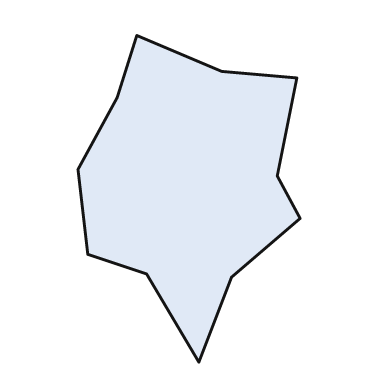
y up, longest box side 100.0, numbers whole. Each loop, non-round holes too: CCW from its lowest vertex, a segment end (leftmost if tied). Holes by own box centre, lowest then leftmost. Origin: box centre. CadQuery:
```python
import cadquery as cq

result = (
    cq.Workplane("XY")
    .moveTo(3.0, -50.0)
    .lineTo(13.0, -24.0)
    .lineTo(34.0, -6.0)
    .lineTo(27.0, 7.0)
    .lineTo(33.0, 37.0)
    .lineTo(10.0, 39.0)
    .lineTo(-16.0, 50.0)
    .lineTo(-22.0, 31.0)
    .lineTo(-34.0, 9.0)
    .lineTo(-31.0, -17.0)
    .lineTo(-13.0, -23.0)
    .close()
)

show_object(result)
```